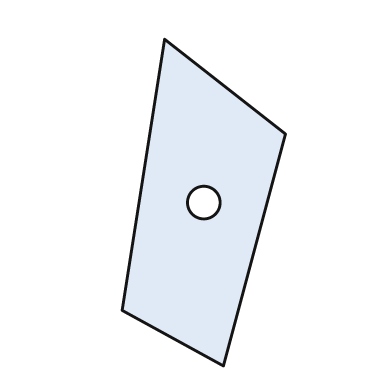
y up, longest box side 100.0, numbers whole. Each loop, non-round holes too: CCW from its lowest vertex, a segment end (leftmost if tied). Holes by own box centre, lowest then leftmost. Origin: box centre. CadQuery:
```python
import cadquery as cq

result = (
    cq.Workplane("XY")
    .moveTo(6.0, -50.0)
    .lineTo(25.0, 21.0)
    .lineTo(-12.0, 50.0)
    .lineTo(-25.0, -33.0)
    .close()
    .moveTo(0.0, 0.0)
    .circle(5.0)
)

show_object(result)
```